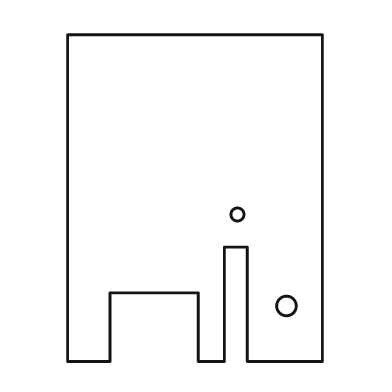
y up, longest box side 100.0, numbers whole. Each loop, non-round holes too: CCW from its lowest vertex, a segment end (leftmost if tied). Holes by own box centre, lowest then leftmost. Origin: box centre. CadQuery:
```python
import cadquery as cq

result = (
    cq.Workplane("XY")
    .moveTo(-39.0, -50.0)
    .lineTo(-26.0, -50.0)
    .lineTo(-26.0, -29.0)
    .lineTo(1.0, -29.0)
    .lineTo(1.0, -50.0)
    .lineTo(9.0, -50.0)
    .lineTo(9.0, -15.0)
    .lineTo(16.0, -15.0)
    .lineTo(16.0, -50.0)
    .lineTo(39.0, -50.0)
    .lineTo(39.0, 50.0)
    .lineTo(-39.0, 50.0)
    .close()
    .moveTo(28.0, -33.0)
    .circle(3.0)
    .moveTo(13.0, -5.0)
    .circle(2.0)
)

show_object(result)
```